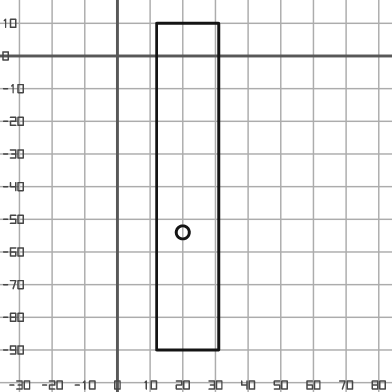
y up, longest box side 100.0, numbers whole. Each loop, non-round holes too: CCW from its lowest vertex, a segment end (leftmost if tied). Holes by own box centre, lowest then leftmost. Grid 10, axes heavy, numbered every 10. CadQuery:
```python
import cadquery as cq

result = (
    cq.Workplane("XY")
    .moveTo(12.0, -90.0)
    .lineTo(31.0, -90.0)
    .lineTo(31.0, 10.0)
    .lineTo(12.0, 10.0)
    .close()
    .moveTo(20.0, -54.0)
    .circle(2.0)
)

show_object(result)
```